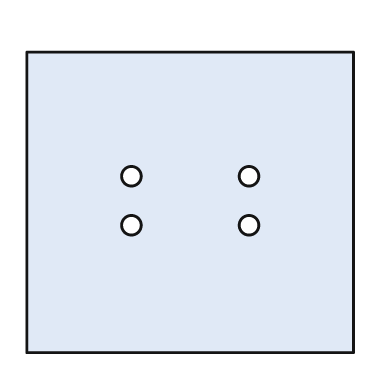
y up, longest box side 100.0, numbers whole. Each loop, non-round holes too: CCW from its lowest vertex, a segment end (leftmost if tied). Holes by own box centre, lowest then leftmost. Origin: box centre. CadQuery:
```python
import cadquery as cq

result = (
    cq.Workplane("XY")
    .moveTo(-50.0, -46.0)
    .lineTo(50.0, -46.0)
    .lineTo(50.0, 46.0)
    .lineTo(-50.0, 46.0)
    .close()
    .moveTo(-18.0, -7.0)
    .circle(3.0)
    .moveTo(18.0, -7.0)
    .circle(3.0)
    .moveTo(-18.0, 8.0)
    .circle(3.0)
    .moveTo(18.0, 8.0)
    .circle(3.0)
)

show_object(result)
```